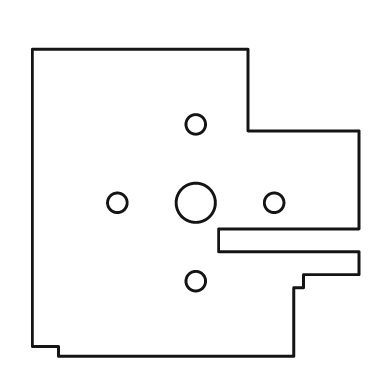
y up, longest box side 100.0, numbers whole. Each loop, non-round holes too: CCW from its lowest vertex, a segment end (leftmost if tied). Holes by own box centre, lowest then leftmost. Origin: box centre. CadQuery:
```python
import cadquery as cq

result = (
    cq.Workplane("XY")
    .moveTo(-42.0, -47.0)
    .lineTo(30.0, -47.0)
    .lineTo(30.0, -26.0)
    .lineTo(33.0, -26.0)
    .lineTo(33.0, -22.0)
    .lineTo(50.0, -22.0)
    .lineTo(50.0, -15.0)
    .lineTo(7.0, -15.0)
    .lineTo(7.0, -8.0)
    .lineTo(50.0, -8.0)
    .lineTo(50.0, 22.0)
    .lineTo(16.0, 22.0)
    .lineTo(16.0, 47.0)
    .lineTo(-50.0, 47.0)
    .lineTo(-50.0, -44.0)
    .lineTo(-42.0, -44.0)
    .close()
    .moveTo(0.0, -24.0)
    .circle(3.0)
    .moveTo(-24.0, 0.0)
    .circle(3.0)
    .moveTo(0.0, 0.0)
    .circle(6.0)
    .moveTo(24.0, 0.0)
    .circle(3.0)
    .moveTo(0.0, 24.0)
    .circle(3.0)
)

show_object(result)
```